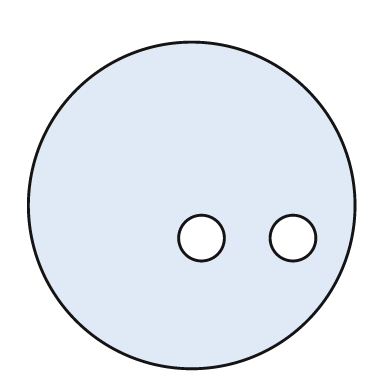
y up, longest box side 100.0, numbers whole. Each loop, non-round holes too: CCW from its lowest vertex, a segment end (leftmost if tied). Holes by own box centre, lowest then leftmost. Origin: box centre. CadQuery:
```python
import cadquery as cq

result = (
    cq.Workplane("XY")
    .moveTo(0.0, 0.0)
    .circle(50.0)
    .moveTo(3.0, -10.0)
    .circle(7.0)
    .moveTo(31.0, -10.0)
    .circle(7.0)
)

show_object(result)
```